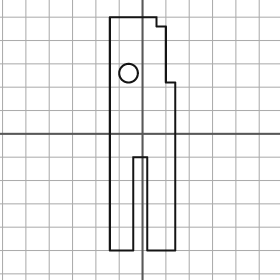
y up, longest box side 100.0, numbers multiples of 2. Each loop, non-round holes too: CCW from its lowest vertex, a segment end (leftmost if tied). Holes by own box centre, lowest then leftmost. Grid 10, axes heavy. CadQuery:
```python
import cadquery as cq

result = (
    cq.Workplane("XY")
    .moveTo(-14.0, -50.0)
    .lineTo(-4.0, -50.0)
    .lineTo(-4.0, -10.0)
    .lineTo(2.0, -10.0)
    .lineTo(2.0, -50.0)
    .lineTo(14.0, -50.0)
    .lineTo(14.0, 22.0)
    .lineTo(10.0, 22.0)
    .lineTo(10.0, 46.0)
    .lineTo(6.0, 46.0)
    .lineTo(6.0, 50.0)
    .lineTo(-14.0, 50.0)
    .close()
    .moveTo(-6.0, 26.0)
    .circle(4.0)
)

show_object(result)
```